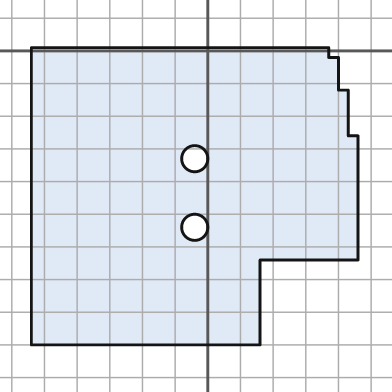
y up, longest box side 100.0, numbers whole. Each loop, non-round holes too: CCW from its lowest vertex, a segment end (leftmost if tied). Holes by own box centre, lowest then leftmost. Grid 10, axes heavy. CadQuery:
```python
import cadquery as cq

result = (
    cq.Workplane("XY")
    .moveTo(-54.0, -90.0)
    .lineTo(16.0, -90.0)
    .lineTo(16.0, -64.0)
    .lineTo(46.0, -64.0)
    .lineTo(46.0, -26.0)
    .lineTo(43.0, -26.0)
    .lineTo(43.0, -12.0)
    .lineTo(40.0, -12.0)
    .lineTo(40.0, -2.0)
    .lineTo(37.0, -2.0)
    .lineTo(37.0, 1.0)
    .lineTo(-54.0, 1.0)
    .close()
    .moveTo(-4.0, -54.0)
    .circle(4.0)
    .moveTo(-4.0, -33.0)
    .circle(4.0)
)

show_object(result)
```